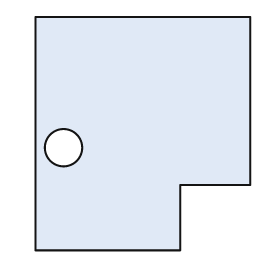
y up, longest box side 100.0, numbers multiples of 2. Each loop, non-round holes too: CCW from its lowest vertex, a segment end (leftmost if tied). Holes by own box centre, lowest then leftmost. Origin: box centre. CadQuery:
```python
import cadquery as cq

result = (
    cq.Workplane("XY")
    .moveTo(-46.0, -50.0)
    .lineTo(16.0, -50.0)
    .lineTo(16.0, -22.0)
    .lineTo(46.0, -22.0)
    .lineTo(46.0, 50.0)
    .lineTo(-46.0, 50.0)
    .close()
    .moveTo(-34.0, -6.0)
    .circle(8.0)
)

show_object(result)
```